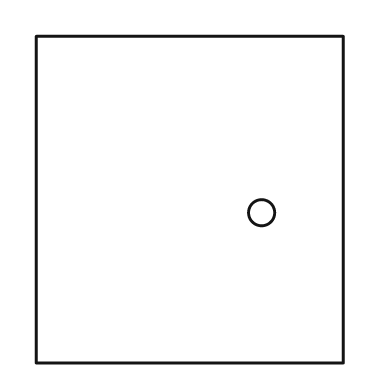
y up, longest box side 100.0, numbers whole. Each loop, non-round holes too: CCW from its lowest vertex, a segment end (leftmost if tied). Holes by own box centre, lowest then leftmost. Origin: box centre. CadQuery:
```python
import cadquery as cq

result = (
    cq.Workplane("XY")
    .moveTo(-47.0, -50.0)
    .lineTo(47.0, -50.0)
    .lineTo(47.0, 50.0)
    .lineTo(-47.0, 50.0)
    .close()
    .moveTo(22.0, -4.0)
    .circle(4.0)
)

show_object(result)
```